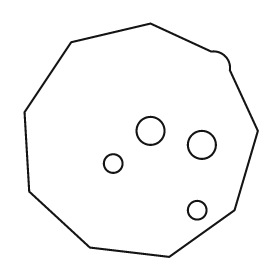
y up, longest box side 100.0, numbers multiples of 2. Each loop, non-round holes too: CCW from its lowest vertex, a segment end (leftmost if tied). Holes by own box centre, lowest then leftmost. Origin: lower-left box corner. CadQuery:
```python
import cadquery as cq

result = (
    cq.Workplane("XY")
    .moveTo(62.0, 0.0)
    .lineTo(90.0, 20.0)
    .lineTo(100.0, 54.0)
    .lineTo(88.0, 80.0)
    .threePointArc((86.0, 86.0), (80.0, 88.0))
    .lineTo(54.0, 100.0)
    .lineTo(20.0, 92.0)
    .lineTo(0.0, 62.0)
    .lineTo(2.0, 28.0)
    .lineTo(28.0, 4.0)
    .close()
    .moveTo(74.0, 20.0)
    .circle(4.0)
    .moveTo(38.0, 40.0)
    .circle(4.0)
    .moveTo(76.0, 48.0)
    .circle(6.0)
    .moveTo(54.0, 54.0)
    .circle(6.0)
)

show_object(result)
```